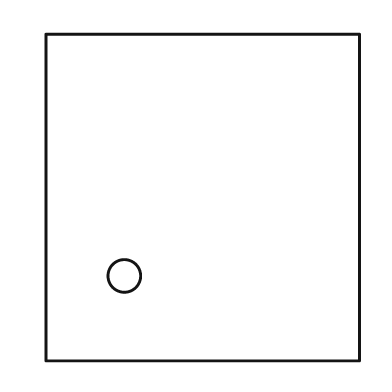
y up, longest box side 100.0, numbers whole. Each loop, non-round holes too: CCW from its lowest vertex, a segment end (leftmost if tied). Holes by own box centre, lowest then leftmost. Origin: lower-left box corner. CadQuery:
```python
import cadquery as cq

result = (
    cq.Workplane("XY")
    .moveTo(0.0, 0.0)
    .lineTo(96.0, 0.0)
    .lineTo(96.0, 100.0)
    .lineTo(0.0, 100.0)
    .close()
    .moveTo(24.0, 26.0)
    .circle(5.0)
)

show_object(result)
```